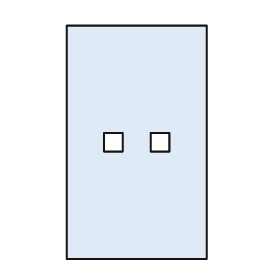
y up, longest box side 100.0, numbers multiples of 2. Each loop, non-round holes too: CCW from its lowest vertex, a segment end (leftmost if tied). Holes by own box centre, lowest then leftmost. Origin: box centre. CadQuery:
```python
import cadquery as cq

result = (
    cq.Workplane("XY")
    .moveTo(-30.0, -50.0)
    .lineTo(30.0, -50.0)
    .lineTo(30.0, 50.0)
    .lineTo(-30.0, 50.0)
    .close()
    .moveTo(-14.0, -4.0)
    .lineTo(-6.0, -4.0)
    .lineTo(-6.0, 4.0)
    .lineTo(-14.0, 4.0)
    .close()
    .moveTo(6.0, -4.0)
    .lineTo(14.0, -4.0)
    .lineTo(14.0, 4.0)
    .lineTo(6.0, 4.0)
    .close()
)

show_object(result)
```